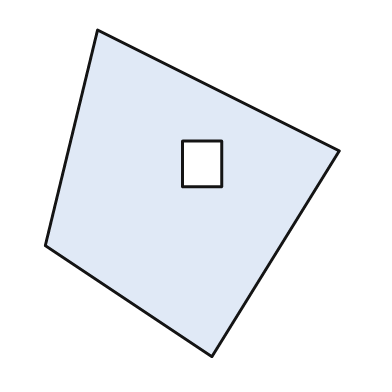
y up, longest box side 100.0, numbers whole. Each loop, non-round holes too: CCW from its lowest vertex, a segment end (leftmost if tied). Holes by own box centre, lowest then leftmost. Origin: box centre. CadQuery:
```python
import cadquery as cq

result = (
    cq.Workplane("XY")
    .moveTo(6.0, -50.0)
    .lineTo(45.0, 13.0)
    .lineTo(-29.0, 50.0)
    .lineTo(-45.0, -16.0)
    .close()
    .moveTo(-3.0, 2.0)
    .lineTo(9.0, 2.0)
    .lineTo(9.0, 16.0)
    .lineTo(-3.0, 16.0)
    .close()
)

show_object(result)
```